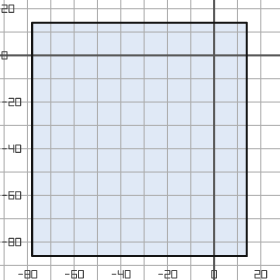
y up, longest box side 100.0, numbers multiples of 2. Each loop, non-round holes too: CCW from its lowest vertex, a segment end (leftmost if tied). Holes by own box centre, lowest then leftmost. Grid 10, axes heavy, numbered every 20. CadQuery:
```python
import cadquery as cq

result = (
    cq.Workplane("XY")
    .moveTo(-78.0, -86.0)
    .lineTo(14.0, -86.0)
    .lineTo(14.0, 14.0)
    .lineTo(-78.0, 14.0)
    .close()
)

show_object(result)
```